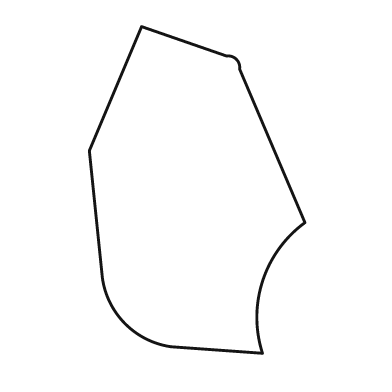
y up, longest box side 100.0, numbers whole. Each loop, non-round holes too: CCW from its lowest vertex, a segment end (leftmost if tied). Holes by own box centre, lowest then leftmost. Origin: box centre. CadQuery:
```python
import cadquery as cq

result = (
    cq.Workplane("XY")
    .moveTo(20.0, -50.0)
    .threePointArc((20.0, -28.0), (33.0, -10.0))
    .lineTo(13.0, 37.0)
    .threePointArc((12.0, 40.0), (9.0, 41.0))
    .lineTo(-17.0, 50.0)
    .lineTo(-33.0, 12.0)
    .lineTo(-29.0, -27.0)
    .threePointArc((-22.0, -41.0), (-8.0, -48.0))
    .close()
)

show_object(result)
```